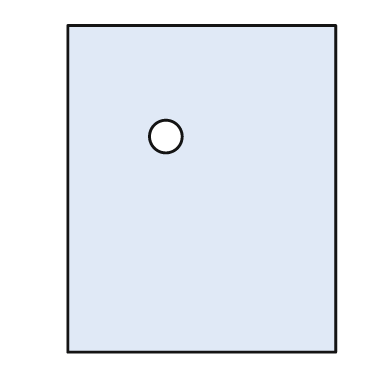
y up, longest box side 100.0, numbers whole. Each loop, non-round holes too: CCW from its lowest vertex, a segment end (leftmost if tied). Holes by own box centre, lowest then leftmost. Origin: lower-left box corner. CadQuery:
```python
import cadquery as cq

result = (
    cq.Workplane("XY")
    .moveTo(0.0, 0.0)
    .lineTo(82.0, 0.0)
    .lineTo(82.0, 100.0)
    .lineTo(0.0, 100.0)
    .close()
    .moveTo(30.0, 66.0)
    .circle(5.0)
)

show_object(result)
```